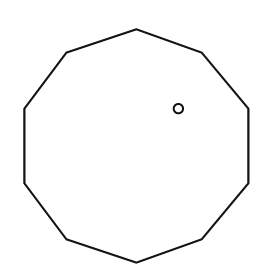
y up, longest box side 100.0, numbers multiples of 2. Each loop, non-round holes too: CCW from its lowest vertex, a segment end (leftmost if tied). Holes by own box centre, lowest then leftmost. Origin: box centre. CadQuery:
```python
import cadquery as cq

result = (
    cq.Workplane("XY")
    .moveTo(0.0, -50.0)
    .lineTo(28.0, -40.0)
    .lineTo(48.0, -16.0)
    .lineTo(48.0, 16.0)
    .lineTo(28.0, 40.0)
    .lineTo(0.0, 50.0)
    .lineTo(-30.0, 40.0)
    .lineTo(-48.0, 16.0)
    .lineTo(-48.0, -16.0)
    .lineTo(-30.0, -40.0)
    .close()
    .moveTo(18.0, 16.0)
    .circle(2.0)
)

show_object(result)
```